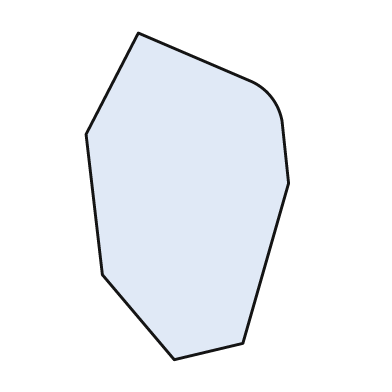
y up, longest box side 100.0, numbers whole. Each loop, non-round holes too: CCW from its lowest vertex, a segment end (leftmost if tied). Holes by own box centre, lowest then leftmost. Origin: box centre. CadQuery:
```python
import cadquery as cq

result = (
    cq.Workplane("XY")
    .moveTo(-4.0, -50.0)
    .lineTo(17.0, -45.0)
    .lineTo(31.0, 4.0)
    .lineTo(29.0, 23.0)
    .threePointArc((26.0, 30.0), (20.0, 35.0))
    .lineTo(-15.0, 50.0)
    .lineTo(-31.0, 19.0)
    .lineTo(-26.0, -24.0)
    .close()
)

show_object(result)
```